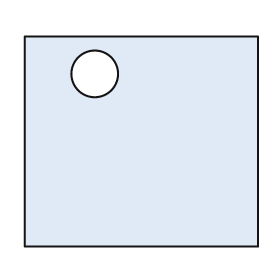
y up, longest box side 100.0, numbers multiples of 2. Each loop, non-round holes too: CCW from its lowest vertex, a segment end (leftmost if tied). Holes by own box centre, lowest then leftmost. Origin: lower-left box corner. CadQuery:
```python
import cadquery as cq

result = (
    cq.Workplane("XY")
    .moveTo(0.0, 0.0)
    .lineTo(100.0, 0.0)
    .lineTo(100.0, 90.0)
    .lineTo(0.0, 90.0)
    .close()
    .moveTo(30.0, 74.0)
    .circle(10.0)
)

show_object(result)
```